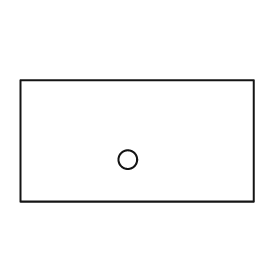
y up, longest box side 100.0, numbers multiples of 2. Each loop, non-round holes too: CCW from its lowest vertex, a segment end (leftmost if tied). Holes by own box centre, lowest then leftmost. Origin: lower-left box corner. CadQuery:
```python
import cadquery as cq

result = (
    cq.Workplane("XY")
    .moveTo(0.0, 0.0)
    .lineTo(100.0, 0.0)
    .lineTo(100.0, 52.0)
    .lineTo(0.0, 52.0)
    .close()
    .moveTo(46.0, 18.0)
    .circle(4.0)
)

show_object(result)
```